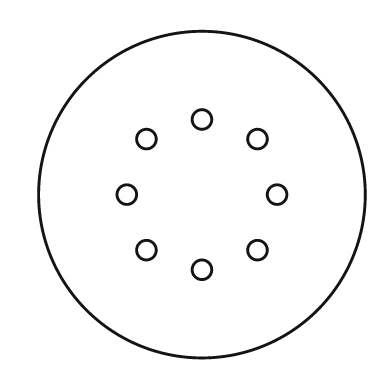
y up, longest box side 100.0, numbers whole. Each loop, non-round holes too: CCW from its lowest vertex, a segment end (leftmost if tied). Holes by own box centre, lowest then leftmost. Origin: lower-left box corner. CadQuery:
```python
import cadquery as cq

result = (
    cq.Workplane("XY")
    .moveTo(50.0, 50.0)
    .circle(50.0)
    .moveTo(50.0, 27.0)
    .circle(3.0)
    .moveTo(33.0, 33.0)
    .circle(3.0)
    .moveTo(67.0, 33.0)
    .circle(3.0)
    .moveTo(27.0, 50.0)
    .circle(3.0)
    .moveTo(73.0, 50.0)
    .circle(3.0)
    .moveTo(33.0, 67.0)
    .circle(3.0)
    .moveTo(67.0, 67.0)
    .circle(3.0)
    .moveTo(50.0, 73.0)
    .circle(3.0)
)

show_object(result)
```